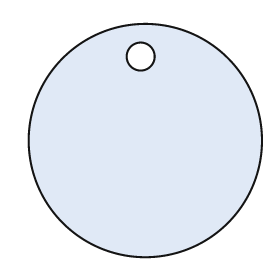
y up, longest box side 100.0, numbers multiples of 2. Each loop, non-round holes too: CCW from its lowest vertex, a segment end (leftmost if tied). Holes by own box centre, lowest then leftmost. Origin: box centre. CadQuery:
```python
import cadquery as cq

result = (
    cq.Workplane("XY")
    .moveTo(0.0, 0.0)
    .circle(50.0)
    .moveTo(-2.0, 36.0)
    .circle(6.0)
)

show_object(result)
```